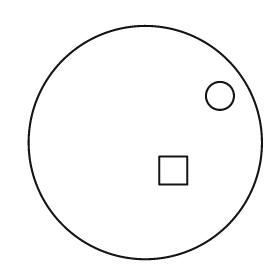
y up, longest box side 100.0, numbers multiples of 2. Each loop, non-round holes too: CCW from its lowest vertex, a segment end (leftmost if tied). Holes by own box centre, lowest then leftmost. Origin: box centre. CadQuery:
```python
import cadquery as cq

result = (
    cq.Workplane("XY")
    .moveTo(0.0, 0.0)
    .circle(50.0)
    .moveTo(6.0, -18.0)
    .lineTo(18.0, -18.0)
    .lineTo(18.0, -6.0)
    .lineTo(6.0, -6.0)
    .close()
    .moveTo(32.0, 20.0)
    .circle(6.0)
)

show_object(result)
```